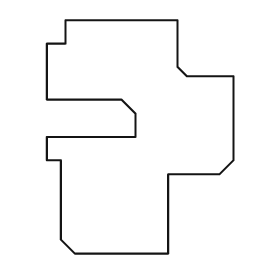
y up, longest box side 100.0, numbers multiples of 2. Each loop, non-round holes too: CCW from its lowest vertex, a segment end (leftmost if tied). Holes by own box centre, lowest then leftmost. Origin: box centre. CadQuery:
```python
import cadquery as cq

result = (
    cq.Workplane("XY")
    .moveTo(-28.0, -50.0)
    .lineTo(12.0, -50.0)
    .lineTo(12.0, -16.0)
    .lineTo(34.0, -16.0)
    .lineTo(40.0, -10.0)
    .lineTo(40.0, 26.0)
    .lineTo(20.0, 26.0)
    .lineTo(16.0, 30.0)
    .lineTo(16.0, 50.0)
    .lineTo(-32.0, 50.0)
    .lineTo(-32.0, 40.0)
    .lineTo(-40.0, 40.0)
    .lineTo(-40.0, 16.0)
    .lineTo(-8.0, 16.0)
    .lineTo(-2.0, 10.0)
    .lineTo(-2.0, 0.0)
    .lineTo(-40.0, 0.0)
    .lineTo(-40.0, -10.0)
    .lineTo(-34.0, -10.0)
    .lineTo(-34.0, -44.0)
    .close()
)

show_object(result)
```